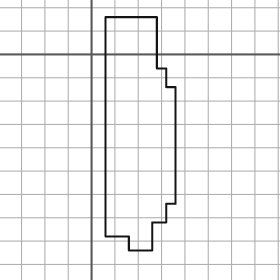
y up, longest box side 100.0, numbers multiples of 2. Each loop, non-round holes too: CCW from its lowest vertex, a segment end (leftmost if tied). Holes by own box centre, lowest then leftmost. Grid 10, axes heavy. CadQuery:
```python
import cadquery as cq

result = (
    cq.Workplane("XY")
    .moveTo(16.0, -84.0)
    .lineTo(26.0, -84.0)
    .lineTo(26.0, -72.0)
    .lineTo(32.0, -72.0)
    .lineTo(32.0, -64.0)
    .lineTo(36.0, -64.0)
    .lineTo(36.0, -14.0)
    .lineTo(32.0, -14.0)
    .lineTo(32.0, -6.0)
    .lineTo(28.0, -6.0)
    .lineTo(28.0, 16.0)
    .lineTo(6.0, 16.0)
    .lineTo(6.0, -78.0)
    .lineTo(16.0, -78.0)
    .close()
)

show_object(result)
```